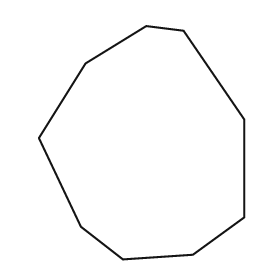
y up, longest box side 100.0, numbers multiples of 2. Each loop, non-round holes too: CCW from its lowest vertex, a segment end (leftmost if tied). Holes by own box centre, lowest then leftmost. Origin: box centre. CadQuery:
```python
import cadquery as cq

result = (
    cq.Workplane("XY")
    .moveTo(-8.0, -50.0)
    .lineTo(22.0, -48.0)
    .lineTo(44.0, -32.0)
    .lineTo(44.0, 10.0)
    .lineTo(18.0, 48.0)
    .lineTo(2.0, 50.0)
    .lineTo(-24.0, 34.0)
    .lineTo(-44.0, 2.0)
    .lineTo(-26.0, -36.0)
    .close()
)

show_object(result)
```